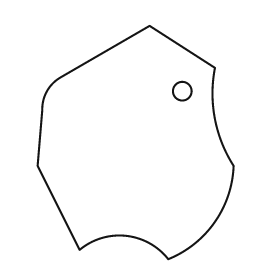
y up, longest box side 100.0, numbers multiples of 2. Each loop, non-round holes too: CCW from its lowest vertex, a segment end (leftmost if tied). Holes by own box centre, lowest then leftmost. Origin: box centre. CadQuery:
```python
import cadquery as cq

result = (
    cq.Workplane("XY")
    .moveTo(14.0, -50.0)
    .threePointArc((34.0, -34.0), (42.0, -10.0))
    .threePointArc((34.0, 10.0), (34.0, 32.0))
    .lineTo(6.0, 50.0)
    .lineTo(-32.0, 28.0)
    .threePointArc((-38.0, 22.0), (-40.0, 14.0))
    .lineTo(-42.0, -10.0)
    .lineTo(-24.0, -46.0)
    .threePointArc((-4.0, -40.0), (14.0, -50.0))
    .close()
    .moveTo(20.0, 22.0)
    .circle(4.0)
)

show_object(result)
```